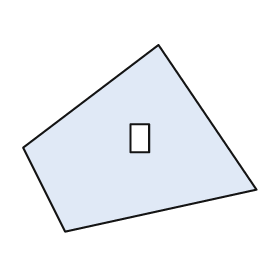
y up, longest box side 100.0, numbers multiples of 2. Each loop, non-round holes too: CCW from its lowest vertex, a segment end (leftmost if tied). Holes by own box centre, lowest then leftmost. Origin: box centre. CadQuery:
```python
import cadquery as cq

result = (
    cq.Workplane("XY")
    .moveTo(-32.0, -40.0)
    .lineTo(50.0, -22.0)
    .lineTo(8.0, 40.0)
    .lineTo(-50.0, -4.0)
    .close()
    .moveTo(-4.0, -6.0)
    .lineTo(4.0, -6.0)
    .lineTo(4.0, 6.0)
    .lineTo(-4.0, 6.0)
    .close()
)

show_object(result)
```